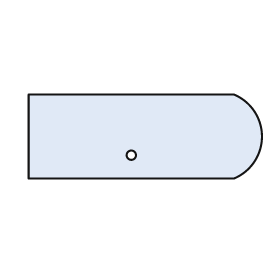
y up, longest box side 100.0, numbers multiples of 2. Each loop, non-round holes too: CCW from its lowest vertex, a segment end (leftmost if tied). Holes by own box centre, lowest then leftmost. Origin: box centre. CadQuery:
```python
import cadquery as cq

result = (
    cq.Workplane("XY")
    .moveTo(-50.0, -18.0)
    .lineTo(38.0, -18.0)
    .threePointArc((50.0, 0.0), (38.0, 18.0))
    .lineTo(-50.0, 18.0)
    .close()
    .moveTo(-6.0, -8.0)
    .circle(2.0)
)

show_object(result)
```